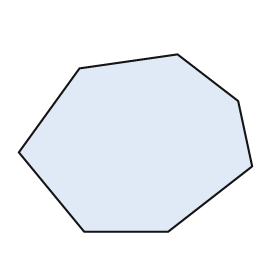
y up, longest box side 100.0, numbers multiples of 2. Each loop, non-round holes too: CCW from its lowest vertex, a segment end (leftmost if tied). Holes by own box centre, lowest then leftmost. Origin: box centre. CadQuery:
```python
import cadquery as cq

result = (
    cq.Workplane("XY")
    .moveTo(-22.0, -38.0)
    .lineTo(14.0, -38.0)
    .lineTo(50.0, -10.0)
    .lineTo(44.0, 18.0)
    .lineTo(18.0, 38.0)
    .lineTo(-24.0, 32.0)
    .lineTo(-50.0, -4.0)
    .close()
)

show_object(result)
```